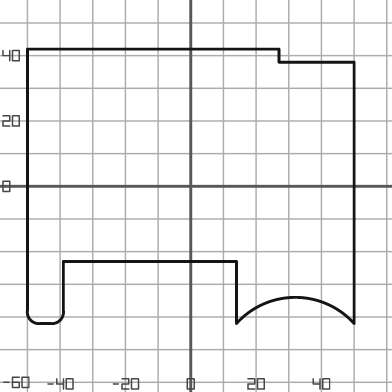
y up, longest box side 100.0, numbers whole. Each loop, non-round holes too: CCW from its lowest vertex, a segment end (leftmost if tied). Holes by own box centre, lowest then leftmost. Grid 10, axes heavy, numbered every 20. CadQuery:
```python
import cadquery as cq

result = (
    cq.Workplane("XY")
    .moveTo(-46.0, -42.0)
    .lineTo(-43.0, -42.0)
    .threePointArc((-40.0, -41.0), (-39.0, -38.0))
    .lineTo(-39.0, -23.0)
    .lineTo(14.0, -23.0)
    .lineTo(14.0, -42.0)
    .threePointArc((32.0, -34.0), (50.0, -42.0))
    .lineTo(50.0, 38.0)
    .lineTo(27.0, 38.0)
    .lineTo(27.0, 42.0)
    .lineTo(-50.0, 42.0)
    .lineTo(-50.0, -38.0)
    .threePointArc((-49.0, -41.0), (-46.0, -42.0))
    .close()
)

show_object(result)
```